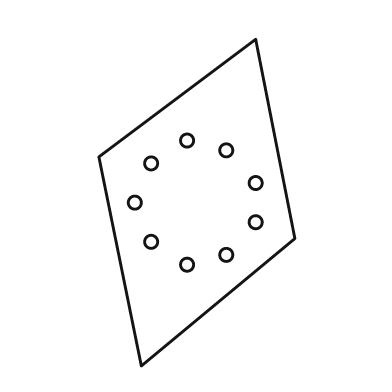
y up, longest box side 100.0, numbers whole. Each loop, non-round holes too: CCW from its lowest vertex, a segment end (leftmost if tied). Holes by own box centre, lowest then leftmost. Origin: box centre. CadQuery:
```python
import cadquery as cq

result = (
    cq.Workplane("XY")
    .moveTo(-17.0, -50.0)
    .lineTo(30.0, -11.0)
    .lineTo(18.0, 50.0)
    .lineTo(-30.0, 14.0)
    .close()
    .moveTo(-3.0, -19.0)
    .circle(2.0)
    .moveTo(9.0, -16.0)
    .circle(2.0)
    .moveTo(-14.0, -12.0)
    .circle(2.0)
    .moveTo(18.0, -6.0)
    .circle(2.0)
    .moveTo(-19.0, 0.0)
    .circle(2.0)
    .moveTo(18.0, 6.0)
    .circle(2.0)
    .moveTo(-14.0, 12.0)
    .circle(2.0)
    .moveTo(9.0, 16.0)
    .circle(2.0)
    .moveTo(-3.0, 19.0)
    .circle(2.0)
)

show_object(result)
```